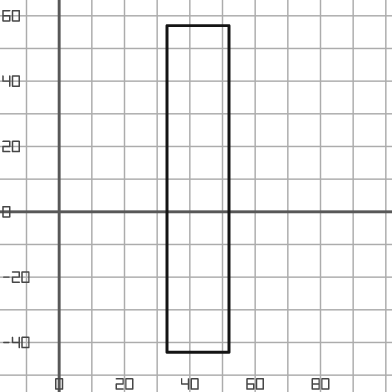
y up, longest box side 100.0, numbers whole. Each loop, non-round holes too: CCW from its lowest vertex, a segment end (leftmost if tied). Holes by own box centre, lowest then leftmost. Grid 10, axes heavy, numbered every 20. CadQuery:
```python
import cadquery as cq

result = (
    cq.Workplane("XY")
    .moveTo(33.0, -43.0)
    .lineTo(52.0, -43.0)
    .lineTo(52.0, 57.0)
    .lineTo(33.0, 57.0)
    .close()
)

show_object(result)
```